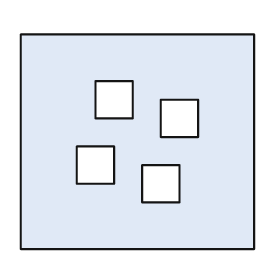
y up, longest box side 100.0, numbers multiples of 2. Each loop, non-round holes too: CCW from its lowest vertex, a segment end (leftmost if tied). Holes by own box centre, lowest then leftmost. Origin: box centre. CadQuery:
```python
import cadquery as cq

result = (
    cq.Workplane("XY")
    .moveTo(-50.0, -46.0)
    .lineTo(50.0, -46.0)
    .lineTo(50.0, 46.0)
    .lineTo(-50.0, 46.0)
    .close()
    .moveTo(2.0, -26.0)
    .lineTo(18.0, -26.0)
    .lineTo(18.0, -10.0)
    .lineTo(2.0, -10.0)
    .close()
    .moveTo(-26.0, -18.0)
    .lineTo(-10.0, -18.0)
    .lineTo(-10.0, -2.0)
    .lineTo(-26.0, -2.0)
    .close()
    .moveTo(10.0, 2.0)
    .lineTo(26.0, 2.0)
    .lineTo(26.0, 18.0)
    .lineTo(10.0, 18.0)
    .close()
    .moveTo(-18.0, 10.0)
    .lineTo(-2.0, 10.0)
    .lineTo(-2.0, 26.0)
    .lineTo(-18.0, 26.0)
    .close()
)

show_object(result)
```